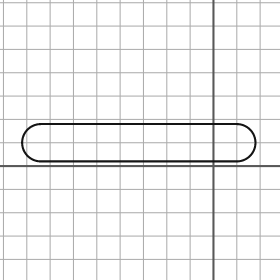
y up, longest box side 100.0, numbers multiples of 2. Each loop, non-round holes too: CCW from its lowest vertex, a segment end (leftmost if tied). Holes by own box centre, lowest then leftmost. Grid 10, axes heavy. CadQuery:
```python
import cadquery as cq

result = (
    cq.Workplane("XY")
    .moveTo(-74.0, 2.0)
    .lineTo(10.0, 2.0)
    .threePointArc((18.0, 10.0), (10.0, 18.0))
    .lineTo(-74.0, 18.0)
    .threePointArc((-82.0, 10.0), (-74.0, 2.0))
    .close()
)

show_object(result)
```